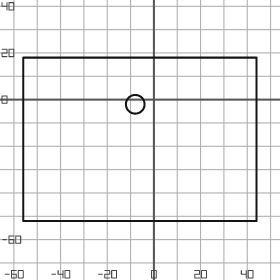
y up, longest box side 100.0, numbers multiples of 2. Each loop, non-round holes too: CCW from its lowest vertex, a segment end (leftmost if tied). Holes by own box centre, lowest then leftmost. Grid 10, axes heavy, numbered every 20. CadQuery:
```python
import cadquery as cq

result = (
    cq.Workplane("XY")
    .moveTo(-56.0, -52.0)
    .lineTo(44.0, -52.0)
    .lineTo(44.0, 18.0)
    .lineTo(-56.0, 18.0)
    .close()
    .moveTo(-8.0, -2.0)
    .circle(4.0)
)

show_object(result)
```